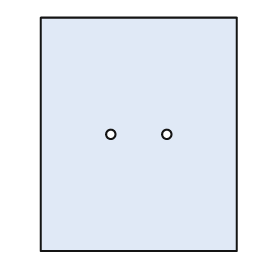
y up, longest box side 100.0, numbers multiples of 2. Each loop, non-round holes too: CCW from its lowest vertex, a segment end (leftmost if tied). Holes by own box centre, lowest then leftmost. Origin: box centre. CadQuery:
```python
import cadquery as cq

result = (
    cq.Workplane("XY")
    .moveTo(-42.0, -50.0)
    .lineTo(42.0, -50.0)
    .lineTo(42.0, 50.0)
    .lineTo(-42.0, 50.0)
    .close()
    .moveTo(-12.0, 0.0)
    .circle(2.0)
    .moveTo(12.0, 0.0)
    .circle(2.0)
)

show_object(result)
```